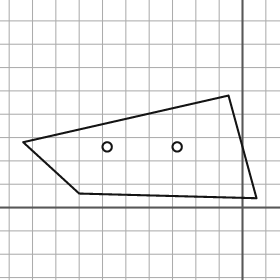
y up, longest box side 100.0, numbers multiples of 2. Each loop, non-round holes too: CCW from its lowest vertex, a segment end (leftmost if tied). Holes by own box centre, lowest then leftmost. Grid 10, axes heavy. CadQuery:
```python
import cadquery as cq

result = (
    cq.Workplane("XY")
    .moveTo(6.0, 4.0)
    .lineTo(-6.0, 48.0)
    .lineTo(-94.0, 28.0)
    .lineTo(-70.0, 6.0)
    .close()
    .moveTo(-58.0, 26.0)
    .circle(2.0)
    .moveTo(-28.0, 26.0)
    .circle(2.0)
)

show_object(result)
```